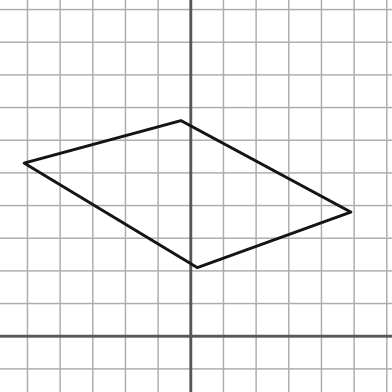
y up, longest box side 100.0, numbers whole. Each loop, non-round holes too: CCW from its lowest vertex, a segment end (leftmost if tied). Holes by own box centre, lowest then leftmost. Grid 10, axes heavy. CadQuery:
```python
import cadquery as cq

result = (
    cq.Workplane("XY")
    .moveTo(2.0, 21.0)
    .lineTo(49.0, 38.0)
    .lineTo(-3.0, 66.0)
    .lineTo(-51.0, 53.0)
    .close()
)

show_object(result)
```